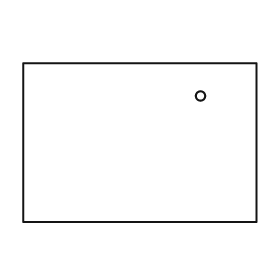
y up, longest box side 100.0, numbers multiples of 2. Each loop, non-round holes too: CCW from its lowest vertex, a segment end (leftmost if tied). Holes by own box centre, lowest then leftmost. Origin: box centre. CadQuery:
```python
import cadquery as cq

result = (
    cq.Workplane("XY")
    .moveTo(-50.0, -34.0)
    .lineTo(50.0, -34.0)
    .lineTo(50.0, 34.0)
    .lineTo(-50.0, 34.0)
    .close()
    .moveTo(26.0, 20.0)
    .circle(2.0)
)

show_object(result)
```